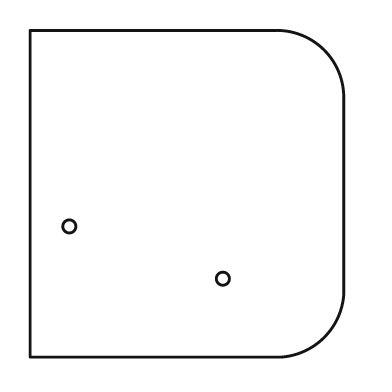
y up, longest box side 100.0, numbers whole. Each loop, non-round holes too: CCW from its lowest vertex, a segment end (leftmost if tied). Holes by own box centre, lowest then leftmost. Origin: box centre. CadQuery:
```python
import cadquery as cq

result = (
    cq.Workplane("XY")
    .moveTo(-48.0, -50.0)
    .lineTo(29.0, -50.0)
    .threePointArc((42.0, -44.0), (48.0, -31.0))
    .lineTo(48.0, 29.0)
    .threePointArc((42.0, 44.0), (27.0, 50.0))
    .lineTo(-48.0, 50.0)
    .close()
    .moveTo(11.0, -26.0)
    .circle(2.0)
    .moveTo(-36.0, -10.0)
    .circle(2.0)
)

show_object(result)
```